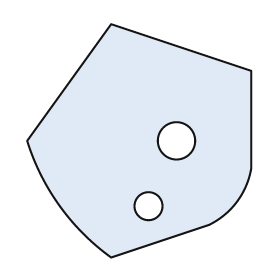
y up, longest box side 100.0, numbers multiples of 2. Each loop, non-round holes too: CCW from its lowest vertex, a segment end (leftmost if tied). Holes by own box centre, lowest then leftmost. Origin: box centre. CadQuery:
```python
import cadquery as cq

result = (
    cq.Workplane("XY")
    .moveTo(-12.0, -50.0)
    .lineTo(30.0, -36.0)
    .threePointArc((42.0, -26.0), (48.0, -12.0))
    .lineTo(48.0, 30.0)
    .lineTo(-12.0, 50.0)
    .lineTo(-48.0, 0.0)
    .threePointArc((-34.0, -28.0), (-12.0, -50.0))
    .close()
    .moveTo(4.0, -28.0)
    .circle(6.0)
    .moveTo(16.0, 0.0)
    .circle(8.0)
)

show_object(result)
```